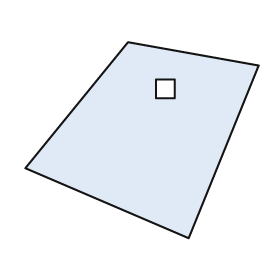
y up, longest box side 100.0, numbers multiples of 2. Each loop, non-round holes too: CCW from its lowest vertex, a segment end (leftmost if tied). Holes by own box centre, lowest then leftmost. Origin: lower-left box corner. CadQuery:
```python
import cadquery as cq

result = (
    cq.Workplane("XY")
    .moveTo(70.0, 0.0)
    .lineTo(100.0, 74.0)
    .lineTo(44.0, 84.0)
    .lineTo(0.0, 30.0)
    .close()
    .moveTo(56.0, 60.0)
    .lineTo(64.0, 60.0)
    .lineTo(64.0, 68.0)
    .lineTo(56.0, 68.0)
    .close()
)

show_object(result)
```